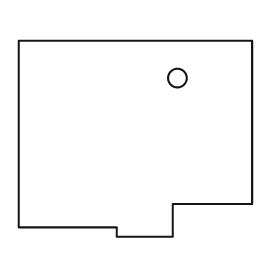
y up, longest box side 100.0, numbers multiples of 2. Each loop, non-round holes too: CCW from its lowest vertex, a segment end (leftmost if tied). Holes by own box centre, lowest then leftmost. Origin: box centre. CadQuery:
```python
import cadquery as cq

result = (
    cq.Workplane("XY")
    .moveTo(-8.0, -42.0)
    .lineTo(16.0, -42.0)
    .lineTo(16.0, -28.0)
    .lineTo(50.0, -28.0)
    .lineTo(50.0, 42.0)
    .lineTo(-50.0, 42.0)
    .lineTo(-50.0, -38.0)
    .lineTo(-8.0, -38.0)
    .close()
    .moveTo(18.0, 26.0)
    .circle(4.0)
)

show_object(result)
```